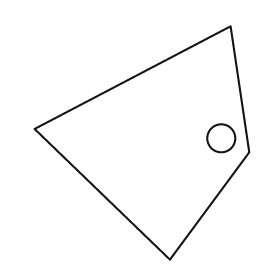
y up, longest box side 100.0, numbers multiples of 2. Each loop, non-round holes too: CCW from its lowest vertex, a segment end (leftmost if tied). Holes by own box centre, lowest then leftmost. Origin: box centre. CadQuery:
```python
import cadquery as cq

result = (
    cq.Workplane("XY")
    .moveTo(12.0, -50.0)
    .lineTo(46.0, -4.0)
    .lineTo(38.0, 50.0)
    .lineTo(-46.0, 6.0)
    .close()
    .moveTo(34.0, 2.0)
    .circle(6.0)
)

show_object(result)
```